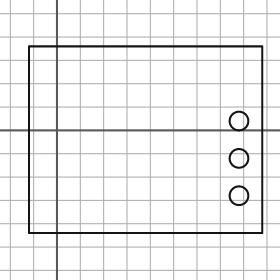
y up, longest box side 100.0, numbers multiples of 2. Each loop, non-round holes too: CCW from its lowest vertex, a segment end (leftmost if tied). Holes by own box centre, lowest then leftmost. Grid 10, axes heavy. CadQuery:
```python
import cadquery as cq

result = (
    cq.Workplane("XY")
    .moveTo(-12.0, -44.0)
    .lineTo(88.0, -44.0)
    .lineTo(88.0, 36.0)
    .lineTo(-12.0, 36.0)
    .close()
    .moveTo(78.0, -28.0)
    .circle(4.0)
    .moveTo(78.0, -12.0)
    .circle(4.0)
    .moveTo(78.0, 4.0)
    .circle(4.0)
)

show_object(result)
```